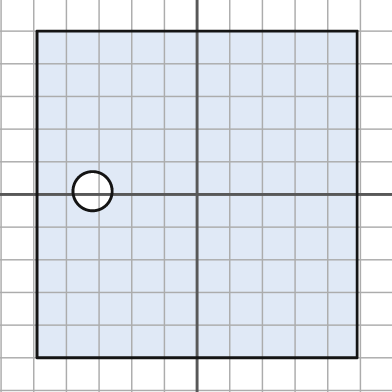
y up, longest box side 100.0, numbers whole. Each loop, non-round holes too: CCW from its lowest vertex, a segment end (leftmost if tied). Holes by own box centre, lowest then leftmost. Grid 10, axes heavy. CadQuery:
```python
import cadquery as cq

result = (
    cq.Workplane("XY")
    .moveTo(-49.0, -50.0)
    .lineTo(49.0, -50.0)
    .lineTo(49.0, 50.0)
    .lineTo(-49.0, 50.0)
    .close()
    .moveTo(-32.0, 1.0)
    .circle(6.0)
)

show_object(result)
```